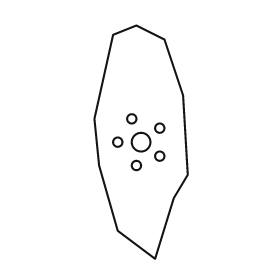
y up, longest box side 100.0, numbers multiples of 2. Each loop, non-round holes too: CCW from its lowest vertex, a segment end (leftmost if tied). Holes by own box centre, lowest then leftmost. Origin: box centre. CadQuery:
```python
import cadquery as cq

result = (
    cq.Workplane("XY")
    .moveTo(6.0, -50.0)
    .lineTo(14.0, -24.0)
    .lineTo(20.0, -14.0)
    .lineTo(18.0, 20.0)
    .lineTo(10.0, 44.0)
    .lineTo(-2.0, 50.0)
    .lineTo(-12.0, 46.0)
    .lineTo(-20.0, 10.0)
    .lineTo(-18.0, -10.0)
    .lineTo(-10.0, -38.0)
    .close()
    .moveTo(-2.0, -10.0)
    .circle(2.0)
    .moveTo(8.0, -6.0)
    .circle(2.0)
    .moveTo(-10.0, 0.0)
    .circle(2.0)
    .moveTo(0.0, 0.0)
    .circle(4.0)
    .moveTo(8.0, 6.0)
    .circle(2.0)
    .moveTo(-4.0, 10.0)
    .circle(2.0)
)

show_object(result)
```